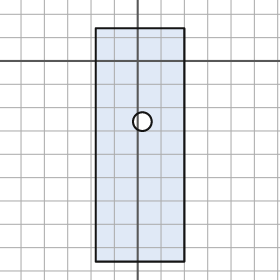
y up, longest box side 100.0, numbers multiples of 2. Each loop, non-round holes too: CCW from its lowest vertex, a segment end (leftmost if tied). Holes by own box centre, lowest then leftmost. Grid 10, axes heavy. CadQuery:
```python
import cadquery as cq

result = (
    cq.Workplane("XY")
    .moveTo(-18.0, -86.0)
    .lineTo(20.0, -86.0)
    .lineTo(20.0, 14.0)
    .lineTo(-18.0, 14.0)
    .close()
    .moveTo(2.0, -26.0)
    .circle(4.0)
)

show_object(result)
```